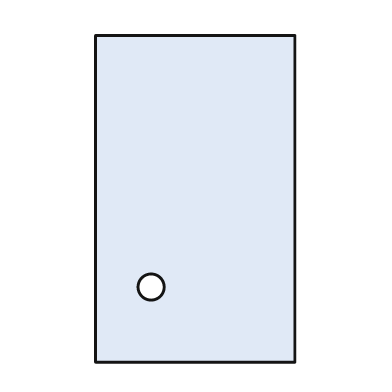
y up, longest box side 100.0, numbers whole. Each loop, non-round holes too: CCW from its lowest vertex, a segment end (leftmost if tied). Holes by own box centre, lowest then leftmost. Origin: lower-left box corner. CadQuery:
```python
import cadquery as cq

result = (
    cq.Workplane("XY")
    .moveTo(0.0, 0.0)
    .lineTo(61.0, 0.0)
    .lineTo(61.0, 100.0)
    .lineTo(0.0, 100.0)
    .close()
    .moveTo(17.0, 23.0)
    .circle(4.0)
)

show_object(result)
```